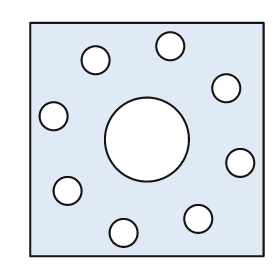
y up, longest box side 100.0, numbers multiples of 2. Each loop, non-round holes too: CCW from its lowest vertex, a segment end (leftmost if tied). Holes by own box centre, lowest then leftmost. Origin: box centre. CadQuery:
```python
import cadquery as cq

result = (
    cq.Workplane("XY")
    .moveTo(-50.0, -50.0)
    .lineTo(50.0, -50.0)
    .lineTo(50.0, 50.0)
    .lineTo(-50.0, 50.0)
    .close()
    .moveTo(-10.0, -40.0)
    .circle(6.0)
    .moveTo(22.0, -34.0)
    .circle(6.0)
    .moveTo(-34.0, -22.0)
    .circle(6.0)
    .moveTo(40.0, -10.0)
    .circle(6.0)
    .moveTo(0.0, 0.0)
    .circle(18.0)
    .moveTo(-40.0, 10.0)
    .circle(6.0)
    .moveTo(34.0, 22.0)
    .circle(6.0)
    .moveTo(-22.0, 34.0)
    .circle(6.0)
    .moveTo(10.0, 40.0)
    .circle(6.0)
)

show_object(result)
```